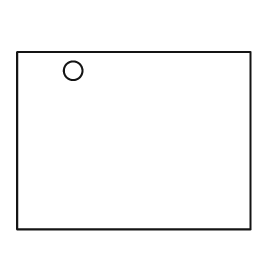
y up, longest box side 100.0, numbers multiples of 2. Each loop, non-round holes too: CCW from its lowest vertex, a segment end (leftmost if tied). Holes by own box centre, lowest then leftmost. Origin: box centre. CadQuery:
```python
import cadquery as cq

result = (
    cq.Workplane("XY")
    .moveTo(-50.0, -38.0)
    .lineTo(50.0, -38.0)
    .lineTo(50.0, 38.0)
    .lineTo(-50.0, 38.0)
    .close()
    .moveTo(-26.0, 30.0)
    .circle(4.0)
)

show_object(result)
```